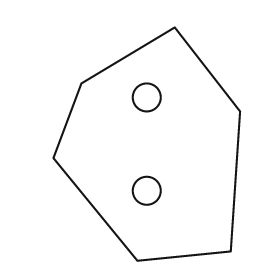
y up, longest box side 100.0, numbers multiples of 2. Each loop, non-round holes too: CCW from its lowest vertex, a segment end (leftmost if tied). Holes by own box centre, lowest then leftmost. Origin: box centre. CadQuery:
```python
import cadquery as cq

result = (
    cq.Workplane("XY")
    .moveTo(-4.0, -50.0)
    .lineTo(36.0, -46.0)
    .lineTo(40.0, 14.0)
    .lineTo(12.0, 50.0)
    .lineTo(-28.0, 26.0)
    .lineTo(-40.0, -6.0)
    .close()
    .moveTo(0.0, -20.0)
    .circle(6.0)
    .moveTo(0.0, 20.0)
    .circle(6.0)
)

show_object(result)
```